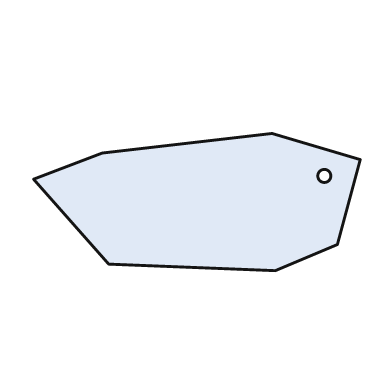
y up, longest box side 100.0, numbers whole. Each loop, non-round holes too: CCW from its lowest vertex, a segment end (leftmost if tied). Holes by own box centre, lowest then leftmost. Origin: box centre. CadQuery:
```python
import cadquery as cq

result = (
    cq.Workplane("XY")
    .moveTo(24.0, -21.0)
    .lineTo(43.0, -13.0)
    .lineTo(50.0, 13.0)
    .lineTo(23.0, 21.0)
    .lineTo(-29.0, 15.0)
    .lineTo(-50.0, 7.0)
    .lineTo(-27.0, -19.0)
    .close()
    .moveTo(39.0, 8.0)
    .circle(2.0)
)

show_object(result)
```